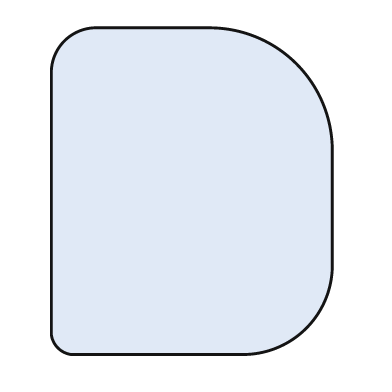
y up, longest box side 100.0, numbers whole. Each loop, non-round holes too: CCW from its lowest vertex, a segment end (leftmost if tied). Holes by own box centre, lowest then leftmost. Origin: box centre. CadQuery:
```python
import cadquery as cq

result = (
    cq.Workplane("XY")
    .moveTo(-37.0, -50.0)
    .lineTo(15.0, -50.0)
    .threePointArc((35.0, -42.0), (43.0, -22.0))
    .lineTo(43.0, 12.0)
    .threePointArc((32.0, 39.0), (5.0, 50.0))
    .lineTo(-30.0, 50.0)
    .threePointArc((-39.0, 46.0), (-43.0, 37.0))
    .lineTo(-43.0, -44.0)
    .threePointArc((-41.0, -48.0), (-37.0, -50.0))
    .close()
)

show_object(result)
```